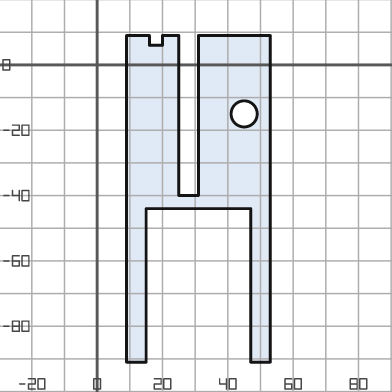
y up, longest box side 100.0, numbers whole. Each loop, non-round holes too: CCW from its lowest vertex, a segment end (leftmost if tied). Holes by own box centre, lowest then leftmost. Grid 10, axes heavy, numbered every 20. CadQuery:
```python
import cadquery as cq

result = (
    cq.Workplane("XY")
    .moveTo(9.0, -91.0)
    .lineTo(15.0, -91.0)
    .lineTo(15.0, -44.0)
    .lineTo(47.0, -44.0)
    .lineTo(47.0, -91.0)
    .lineTo(53.0, -91.0)
    .lineTo(53.0, 9.0)
    .lineTo(31.0, 9.0)
    .lineTo(31.0, -40.0)
    .lineTo(25.0, -40.0)
    .lineTo(25.0, 9.0)
    .lineTo(20.0, 9.0)
    .lineTo(20.0, 6.0)
    .lineTo(16.0, 6.0)
    .lineTo(16.0, 9.0)
    .lineTo(9.0, 9.0)
    .close()
    .moveTo(45.0, -15.0)
    .circle(4.0)
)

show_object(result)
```